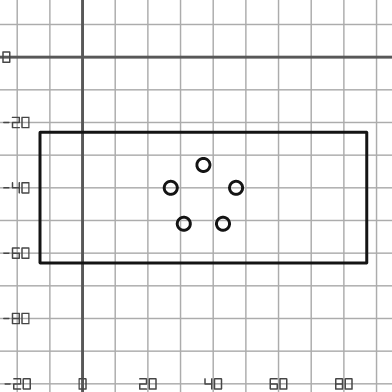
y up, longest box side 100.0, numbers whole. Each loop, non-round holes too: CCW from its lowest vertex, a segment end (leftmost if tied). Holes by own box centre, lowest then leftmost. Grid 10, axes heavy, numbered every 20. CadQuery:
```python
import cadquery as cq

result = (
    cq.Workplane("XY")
    .moveTo(-13.0, -63.0)
    .lineTo(87.0, -63.0)
    .lineTo(87.0, -23.0)
    .lineTo(-13.0, -23.0)
    .close()
    .moveTo(31.0, -51.0)
    .circle(2.0)
    .moveTo(43.0, -51.0)
    .circle(2.0)
    .moveTo(27.0, -40.0)
    .circle(2.0)
    .moveTo(47.0, -40.0)
    .circle(2.0)
    .moveTo(37.0, -33.0)
    .circle(2.0)
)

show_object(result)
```